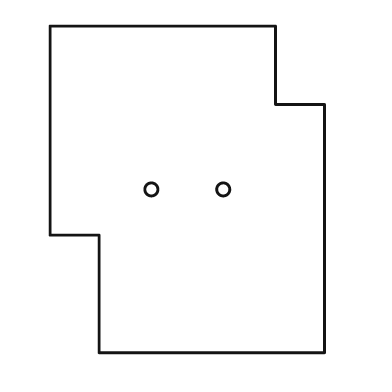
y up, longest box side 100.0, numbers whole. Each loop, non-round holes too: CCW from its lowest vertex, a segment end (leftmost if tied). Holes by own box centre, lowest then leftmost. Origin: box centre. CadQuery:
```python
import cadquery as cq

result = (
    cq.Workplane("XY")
    .moveTo(-27.0, -50.0)
    .lineTo(42.0, -50.0)
    .lineTo(42.0, 26.0)
    .lineTo(27.0, 26.0)
    .lineTo(27.0, 50.0)
    .lineTo(-42.0, 50.0)
    .lineTo(-42.0, -14.0)
    .lineTo(-27.0, -14.0)
    .close()
    .moveTo(-11.0, 0.0)
    .circle(2.0)
    .moveTo(11.0, 0.0)
    .circle(2.0)
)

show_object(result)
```